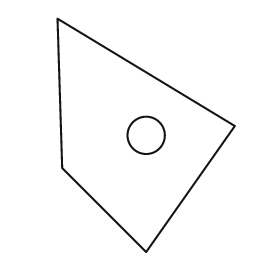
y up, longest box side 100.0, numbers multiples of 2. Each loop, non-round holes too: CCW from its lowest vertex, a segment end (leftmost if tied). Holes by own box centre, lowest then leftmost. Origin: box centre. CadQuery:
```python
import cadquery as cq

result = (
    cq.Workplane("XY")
    .moveTo(0.0, -50.0)
    .lineTo(38.0, 4.0)
    .lineTo(-38.0, 50.0)
    .lineTo(-36.0, -14.0)
    .close()
    .moveTo(0.0, 0.0)
    .circle(8.0)
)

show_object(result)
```